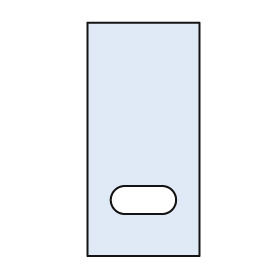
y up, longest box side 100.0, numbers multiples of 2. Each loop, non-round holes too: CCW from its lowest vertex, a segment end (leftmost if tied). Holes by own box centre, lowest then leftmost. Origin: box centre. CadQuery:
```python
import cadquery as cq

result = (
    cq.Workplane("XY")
    .moveTo(-24.0, -50.0)
    .lineTo(24.0, -50.0)
    .lineTo(24.0, 50.0)
    .lineTo(-24.0, 50.0)
    .close()
    .moveTo(-8.0, -32.0)
    .lineTo(8.0, -32.0)
    .threePointArc((14.0, -26.0), (8.0, -20.0))
    .lineTo(-8.0, -20.0)
    .threePointArc((-14.0, -26.0), (-8.0, -32.0))
    .close()
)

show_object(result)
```